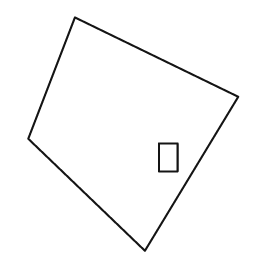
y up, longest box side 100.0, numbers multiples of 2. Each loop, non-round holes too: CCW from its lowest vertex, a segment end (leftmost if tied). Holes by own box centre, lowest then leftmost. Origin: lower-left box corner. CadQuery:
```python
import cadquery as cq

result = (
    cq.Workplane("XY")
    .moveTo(50.0, 0.0)
    .lineTo(90.0, 66.0)
    .lineTo(20.0, 100.0)
    .lineTo(0.0, 48.0)
    .close()
    .moveTo(56.0, 34.0)
    .lineTo(64.0, 34.0)
    .lineTo(64.0, 46.0)
    .lineTo(56.0, 46.0)
    .close()
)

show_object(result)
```